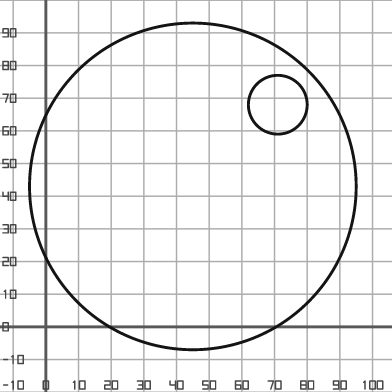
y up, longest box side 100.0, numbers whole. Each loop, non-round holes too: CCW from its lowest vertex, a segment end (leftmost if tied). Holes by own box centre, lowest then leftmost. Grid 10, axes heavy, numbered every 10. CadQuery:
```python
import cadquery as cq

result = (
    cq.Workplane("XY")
    .moveTo(45.0, 43.0)
    .circle(50.0)
    .moveTo(71.0, 68.0)
    .circle(9.0)
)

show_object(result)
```